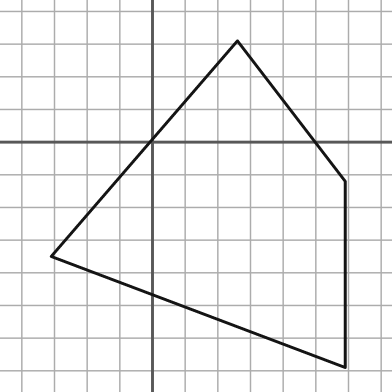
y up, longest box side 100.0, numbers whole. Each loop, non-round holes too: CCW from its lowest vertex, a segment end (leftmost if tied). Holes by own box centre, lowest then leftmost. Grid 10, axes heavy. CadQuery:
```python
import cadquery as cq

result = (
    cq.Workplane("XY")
    .moveTo(59.0, -69.0)
    .lineTo(59.0, -12.0)
    .lineTo(26.0, 31.0)
    .lineTo(-31.0, -35.0)
    .close()
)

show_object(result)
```